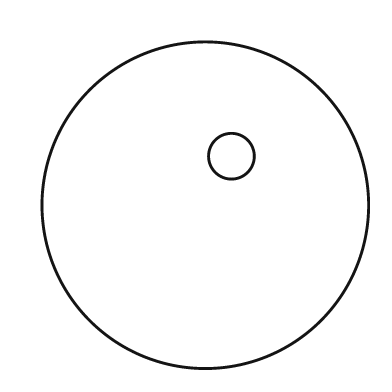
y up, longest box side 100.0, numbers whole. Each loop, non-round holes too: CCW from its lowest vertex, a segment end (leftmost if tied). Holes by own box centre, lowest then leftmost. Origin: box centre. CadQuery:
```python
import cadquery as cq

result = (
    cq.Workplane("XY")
    .moveTo(0.0, 0.0)
    .circle(50.0)
    .moveTo(8.0, 15.0)
    .circle(7.0)
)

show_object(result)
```